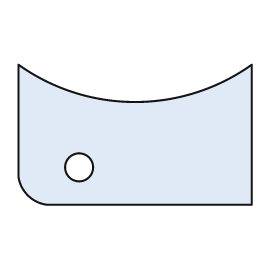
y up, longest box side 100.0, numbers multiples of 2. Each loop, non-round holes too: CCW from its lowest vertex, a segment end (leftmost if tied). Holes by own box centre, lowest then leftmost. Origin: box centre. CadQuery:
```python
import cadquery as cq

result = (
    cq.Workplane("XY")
    .moveTo(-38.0, -30.0)
    .lineTo(50.0, -30.0)
    .lineTo(50.0, 30.0)
    .threePointArc((0.0, 14.0), (-50.0, 30.0))
    .lineTo(-50.0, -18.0)
    .threePointArc((-46.0, -26.0), (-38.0, -30.0))
    .close()
    .moveTo(-24.0, -14.0)
    .circle(6.0)
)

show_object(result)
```